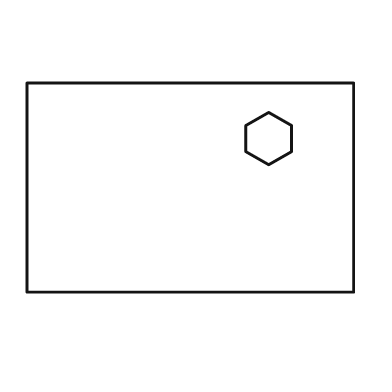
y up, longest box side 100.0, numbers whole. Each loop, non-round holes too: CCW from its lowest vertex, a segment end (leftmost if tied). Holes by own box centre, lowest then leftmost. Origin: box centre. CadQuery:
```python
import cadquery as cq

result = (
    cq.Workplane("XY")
    .moveTo(-50.0, -32.0)
    .lineTo(50.0, -32.0)
    .lineTo(50.0, 32.0)
    .lineTo(-50.0, 32.0)
    .close()
    .moveTo(24.0, 7.0)
    .lineTo(31.0, 11.0)
    .lineTo(31.0, 19.0)
    .lineTo(24.0, 23.0)
    .lineTo(17.0, 19.0)
    .lineTo(17.0, 11.0)
    .close()
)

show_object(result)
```